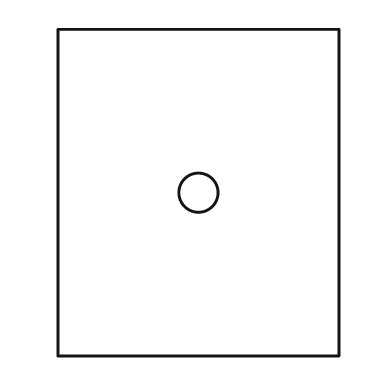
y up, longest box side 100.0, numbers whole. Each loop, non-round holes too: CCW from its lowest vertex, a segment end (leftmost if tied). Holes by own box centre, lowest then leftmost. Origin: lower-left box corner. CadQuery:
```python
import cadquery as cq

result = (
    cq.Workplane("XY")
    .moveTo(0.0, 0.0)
    .lineTo(86.0, 0.0)
    .lineTo(86.0, 100.0)
    .lineTo(0.0, 100.0)
    .close()
    .moveTo(43.0, 50.0)
    .circle(6.0)
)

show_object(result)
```